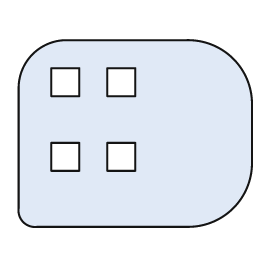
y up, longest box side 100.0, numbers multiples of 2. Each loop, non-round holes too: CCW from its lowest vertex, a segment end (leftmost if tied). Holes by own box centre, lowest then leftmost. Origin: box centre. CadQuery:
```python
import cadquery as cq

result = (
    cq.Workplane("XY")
    .moveTo(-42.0, -40.0)
    .lineTo(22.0, -40.0)
    .threePointArc((42.0, -32.0), (50.0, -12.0))
    .lineTo(50.0, 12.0)
    .threePointArc((42.0, 32.0), (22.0, 40.0))
    .lineTo(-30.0, 40.0)
    .threePointArc((-44.0, 34.0), (-50.0, 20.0))
    .lineTo(-50.0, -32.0)
    .threePointArc((-48.0, -38.0), (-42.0, -40.0))
    .close()
    .moveTo(-36.0, -16.0)
    .lineTo(-24.0, -16.0)
    .lineTo(-24.0, -4.0)
    .lineTo(-36.0, -4.0)
    .close()
    .moveTo(-12.0, -16.0)
    .lineTo(0.0, -16.0)
    .lineTo(0.0, -4.0)
    .lineTo(-12.0, -4.0)
    .close()
    .moveTo(-36.0, 16.0)
    .lineTo(-24.0, 16.0)
    .lineTo(-24.0, 28.0)
    .lineTo(-36.0, 28.0)
    .close()
    .moveTo(-12.0, 16.0)
    .lineTo(0.0, 16.0)
    .lineTo(0.0, 28.0)
    .lineTo(-12.0, 28.0)
    .close()
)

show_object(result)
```